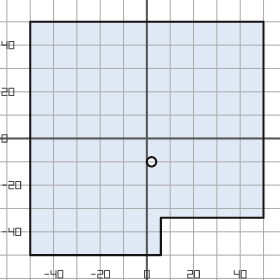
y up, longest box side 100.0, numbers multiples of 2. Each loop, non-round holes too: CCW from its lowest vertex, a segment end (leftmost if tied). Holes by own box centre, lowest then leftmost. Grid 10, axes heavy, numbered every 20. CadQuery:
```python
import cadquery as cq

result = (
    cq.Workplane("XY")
    .moveTo(-50.0, -50.0)
    .lineTo(6.0, -50.0)
    .lineTo(6.0, -34.0)
    .lineTo(50.0, -34.0)
    .lineTo(50.0, 50.0)
    .lineTo(-50.0, 50.0)
    .close()
    .moveTo(2.0, -10.0)
    .circle(2.0)
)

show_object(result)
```